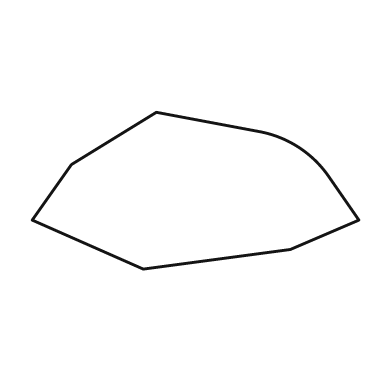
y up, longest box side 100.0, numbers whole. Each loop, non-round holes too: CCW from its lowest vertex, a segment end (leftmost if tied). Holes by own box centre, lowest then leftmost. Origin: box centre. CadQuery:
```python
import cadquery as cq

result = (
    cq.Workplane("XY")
    .moveTo(-16.0, -24.0)
    .lineTo(29.0, -18.0)
    .lineTo(50.0, -9.0)
    .lineTo(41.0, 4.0)
    .threePointArc((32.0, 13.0), (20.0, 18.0))
    .lineTo(-12.0, 24.0)
    .lineTo(-38.0, 8.0)
    .lineTo(-50.0, -9.0)
    .close()
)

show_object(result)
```